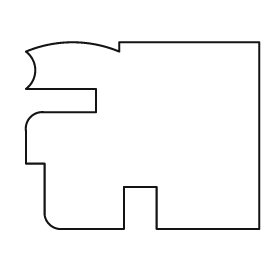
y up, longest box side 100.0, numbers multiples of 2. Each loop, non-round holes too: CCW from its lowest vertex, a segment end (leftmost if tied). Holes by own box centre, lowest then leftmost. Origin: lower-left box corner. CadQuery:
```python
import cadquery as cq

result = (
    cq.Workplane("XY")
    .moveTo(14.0, 0.0)
    .lineTo(42.0, 0.0)
    .lineTo(42.0, 18.0)
    .lineTo(56.0, 18.0)
    .lineTo(56.0, 0.0)
    .lineTo(100.0, 0.0)
    .lineTo(100.0, 80.0)
    .lineTo(40.0, 80.0)
    .lineTo(40.0, 76.0)
    .threePointArc((20.0, 80.0), (0.0, 76.0))
    .threePointArc((4.0, 68.0), (0.0, 60.0))
    .lineTo(30.0, 60.0)
    .lineTo(30.0, 50.0)
    .lineTo(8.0, 50.0)
    .threePointArc((2.0, 48.0), (0.0, 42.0))
    .lineTo(0.0, 28.0)
    .lineTo(8.0, 28.0)
    .lineTo(8.0, 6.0)
    .threePointArc((10.0, 2.0), (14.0, 0.0))
    .close()
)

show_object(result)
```